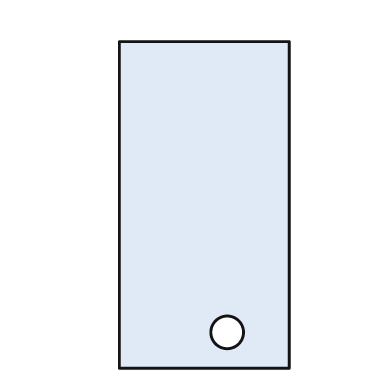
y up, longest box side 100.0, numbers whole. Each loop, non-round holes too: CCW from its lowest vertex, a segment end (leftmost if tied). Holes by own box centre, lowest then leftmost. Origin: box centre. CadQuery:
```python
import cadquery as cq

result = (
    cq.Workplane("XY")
    .moveTo(-26.0, -50.0)
    .lineTo(26.0, -50.0)
    .lineTo(26.0, 50.0)
    .lineTo(-26.0, 50.0)
    .close()
    .moveTo(7.0, -39.0)
    .circle(5.0)
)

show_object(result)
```